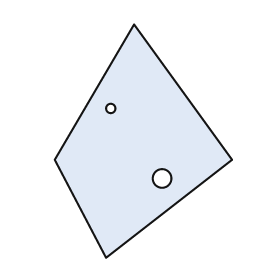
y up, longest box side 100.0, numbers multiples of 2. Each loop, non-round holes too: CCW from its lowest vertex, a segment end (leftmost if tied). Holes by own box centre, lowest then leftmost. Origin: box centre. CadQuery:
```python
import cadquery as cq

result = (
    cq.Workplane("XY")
    .moveTo(-16.0, -50.0)
    .lineTo(38.0, -8.0)
    .lineTo(-4.0, 50.0)
    .lineTo(-38.0, -8.0)
    .close()
    .moveTo(8.0, -16.0)
    .circle(4.0)
    .moveTo(-14.0, 14.0)
    .circle(2.0)
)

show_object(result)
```